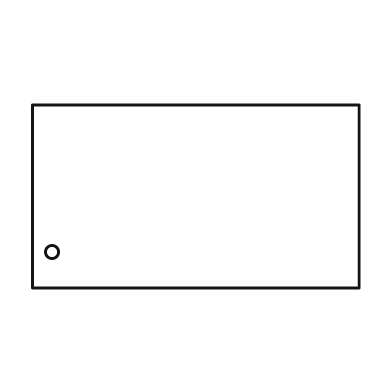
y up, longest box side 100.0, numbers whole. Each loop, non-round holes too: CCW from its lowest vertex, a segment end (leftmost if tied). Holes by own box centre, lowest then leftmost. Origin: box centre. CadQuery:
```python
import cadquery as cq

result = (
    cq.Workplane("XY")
    .moveTo(-50.0, -28.0)
    .lineTo(50.0, -28.0)
    .lineTo(50.0, 28.0)
    .lineTo(-50.0, 28.0)
    .close()
    .moveTo(-44.0, -17.0)
    .circle(2.0)
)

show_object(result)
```